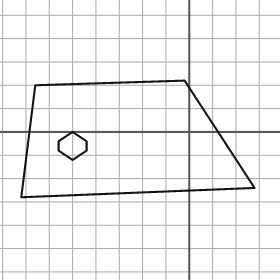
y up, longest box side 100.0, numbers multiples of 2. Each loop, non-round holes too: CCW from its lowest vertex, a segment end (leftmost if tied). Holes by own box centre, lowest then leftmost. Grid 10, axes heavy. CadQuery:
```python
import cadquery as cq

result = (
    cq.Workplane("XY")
    .moveTo(-72.0, -28.0)
    .lineTo(28.0, -24.0)
    .lineTo(-2.0, 22.0)
    .lineTo(-66.0, 20.0)
    .close()
    .moveTo(-50.0, -12.0)
    .lineTo(-44.0, -8.0)
    .lineTo(-44.0, -4.0)
    .lineTo(-50.0, 0.0)
    .lineTo(-56.0, -4.0)
    .lineTo(-56.0, -8.0)
    .close()
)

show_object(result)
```